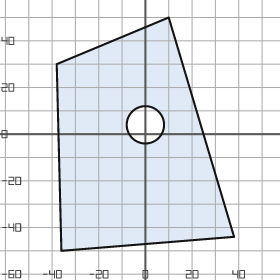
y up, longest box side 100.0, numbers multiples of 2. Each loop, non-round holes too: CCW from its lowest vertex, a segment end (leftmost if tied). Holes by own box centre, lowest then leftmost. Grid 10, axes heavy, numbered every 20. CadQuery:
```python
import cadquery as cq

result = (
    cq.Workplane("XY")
    .moveTo(-36.0, -50.0)
    .lineTo(38.0, -44.0)
    .lineTo(10.0, 50.0)
    .lineTo(-38.0, 30.0)
    .close()
    .moveTo(0.0, 4.0)
    .circle(8.0)
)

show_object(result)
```